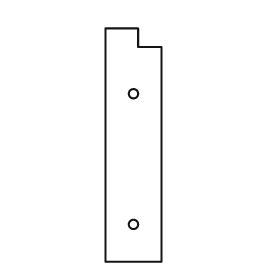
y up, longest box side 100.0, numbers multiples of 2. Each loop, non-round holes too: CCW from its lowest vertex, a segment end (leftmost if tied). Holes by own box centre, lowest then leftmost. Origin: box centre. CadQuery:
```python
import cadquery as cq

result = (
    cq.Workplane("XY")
    .moveTo(-12.0, -50.0)
    .lineTo(12.0, -50.0)
    .lineTo(12.0, 42.0)
    .lineTo(2.0, 42.0)
    .lineTo(2.0, 50.0)
    .lineTo(-12.0, 50.0)
    .close()
    .moveTo(0.0, -34.0)
    .circle(2.0)
    .moveTo(0.0, 22.0)
    .circle(2.0)
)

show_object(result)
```